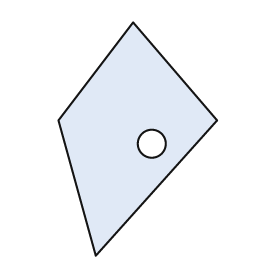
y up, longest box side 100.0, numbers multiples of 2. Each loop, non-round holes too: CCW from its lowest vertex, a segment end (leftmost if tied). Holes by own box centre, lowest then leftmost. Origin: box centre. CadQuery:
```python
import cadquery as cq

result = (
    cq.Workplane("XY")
    .moveTo(-18.0, -50.0)
    .lineTo(34.0, 8.0)
    .lineTo(-2.0, 50.0)
    .lineTo(-34.0, 8.0)
    .close()
    .moveTo(6.0, -2.0)
    .circle(6.0)
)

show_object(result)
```